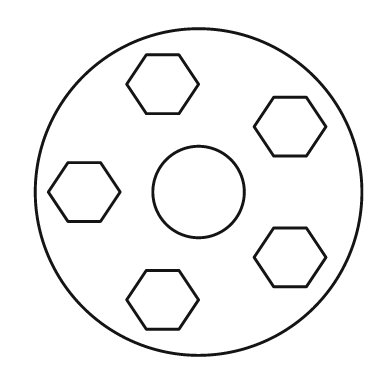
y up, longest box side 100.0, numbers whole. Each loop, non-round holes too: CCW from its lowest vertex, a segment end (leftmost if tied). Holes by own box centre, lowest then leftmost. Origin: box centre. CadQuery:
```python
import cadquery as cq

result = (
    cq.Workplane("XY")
    .moveTo(0.0, 0.0)
    .circle(50.0)
    .moveTo(-16.0, -42.0)
    .lineTo(-6.0, -42.0)
    .lineTo(0.0, -33.0)
    .lineTo(-6.0, -24.0)
    .lineTo(-16.0, -24.0)
    .lineTo(-22.0, -33.0)
    .close()
    .moveTo(23.0, -29.0)
    .lineTo(33.0, -29.0)
    .lineTo(39.0, -20.0)
    .lineTo(33.0, -11.0)
    .lineTo(23.0, -11.0)
    .lineTo(17.0, -20.0)
    .close()
    .moveTo(-40.0, -9.0)
    .lineTo(-30.0, -9.0)
    .lineTo(-24.0, 0.0)
    .lineTo(-30.0, 9.0)
    .lineTo(-40.0, 9.0)
    .lineTo(-46.0, 0.0)
    .close()
    .moveTo(0.0, 0.0)
    .circle(14.0)
    .moveTo(23.0, 11.0)
    .lineTo(33.0, 11.0)
    .lineTo(39.0, 20.0)
    .lineTo(33.0, 29.0)
    .lineTo(23.0, 29.0)
    .lineTo(17.0, 20.0)
    .close()
    .moveTo(-16.0, 24.0)
    .lineTo(-6.0, 24.0)
    .lineTo(0.0, 33.0)
    .lineTo(-6.0, 42.0)
    .lineTo(-16.0, 42.0)
    .lineTo(-22.0, 33.0)
    .close()
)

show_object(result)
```